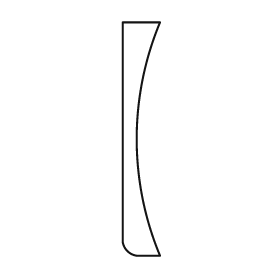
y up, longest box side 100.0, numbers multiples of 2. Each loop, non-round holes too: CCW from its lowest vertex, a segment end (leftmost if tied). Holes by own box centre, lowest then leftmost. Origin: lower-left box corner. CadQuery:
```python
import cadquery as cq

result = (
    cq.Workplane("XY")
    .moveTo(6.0, 0.0)
    .lineTo(16.0, 0.0)
    .threePointArc((6.0, 50.0), (16.0, 100.0))
    .lineTo(0.0, 100.0)
    .lineTo(0.0, 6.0)
    .threePointArc((2.0, 2.0), (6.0, 0.0))
    .close()
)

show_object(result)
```